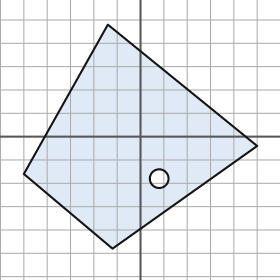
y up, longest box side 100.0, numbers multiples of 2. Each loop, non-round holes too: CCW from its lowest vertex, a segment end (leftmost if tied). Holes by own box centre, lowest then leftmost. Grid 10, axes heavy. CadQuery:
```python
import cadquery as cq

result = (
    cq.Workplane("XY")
    .moveTo(-12.0, -48.0)
    .lineTo(50.0, -4.0)
    .lineTo(-14.0, 48.0)
    .lineTo(-50.0, -16.0)
    .close()
    .moveTo(8.0, -18.0)
    .circle(4.0)
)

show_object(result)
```